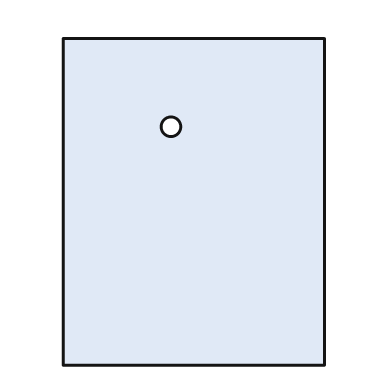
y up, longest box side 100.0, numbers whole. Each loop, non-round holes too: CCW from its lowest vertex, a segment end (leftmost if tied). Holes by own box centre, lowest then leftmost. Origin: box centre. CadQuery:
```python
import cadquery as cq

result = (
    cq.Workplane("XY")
    .moveTo(-40.0, -50.0)
    .lineTo(40.0, -50.0)
    .lineTo(40.0, 50.0)
    .lineTo(-40.0, 50.0)
    .close()
    .moveTo(-7.0, 23.0)
    .circle(3.0)
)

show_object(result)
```